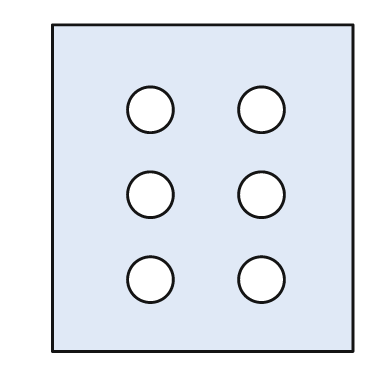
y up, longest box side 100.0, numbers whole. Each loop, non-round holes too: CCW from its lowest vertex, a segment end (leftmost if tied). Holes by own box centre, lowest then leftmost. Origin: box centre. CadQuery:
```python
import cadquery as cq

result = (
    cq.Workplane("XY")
    .moveTo(-46.0, -50.0)
    .lineTo(46.0, -50.0)
    .lineTo(46.0, 50.0)
    .lineTo(-46.0, 50.0)
    .close()
    .moveTo(-16.0, -28.0)
    .circle(7.0)
    .moveTo(18.0, -28.0)
    .circle(7.0)
    .moveTo(-16.0, -2.0)
    .circle(7.0)
    .moveTo(18.0, -2.0)
    .circle(7.0)
    .moveTo(-16.0, 24.0)
    .circle(7.0)
    .moveTo(18.0, 24.0)
    .circle(7.0)
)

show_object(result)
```